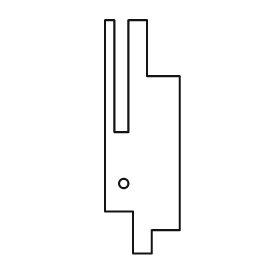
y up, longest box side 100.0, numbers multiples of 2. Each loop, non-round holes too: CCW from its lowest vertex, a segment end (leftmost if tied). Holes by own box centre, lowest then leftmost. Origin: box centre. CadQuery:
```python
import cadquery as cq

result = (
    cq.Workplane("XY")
    .moveTo(-4.0, -50.0)
    .lineTo(4.0, -50.0)
    .lineTo(4.0, -40.0)
    .lineTo(16.0, -40.0)
    .lineTo(16.0, 26.0)
    .lineTo(2.0, 26.0)
    .lineTo(2.0, 50.0)
    .lineTo(-6.0, 50.0)
    .lineTo(-6.0, 2.0)
    .lineTo(-12.0, 2.0)
    .lineTo(-12.0, 50.0)
    .lineTo(-16.0, 50.0)
    .lineTo(-16.0, -32.0)
    .lineTo(-4.0, -32.0)
    .close()
    .moveTo(-8.0, -20.0)
    .circle(2.0)
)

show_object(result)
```